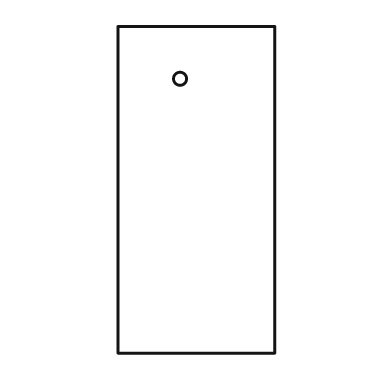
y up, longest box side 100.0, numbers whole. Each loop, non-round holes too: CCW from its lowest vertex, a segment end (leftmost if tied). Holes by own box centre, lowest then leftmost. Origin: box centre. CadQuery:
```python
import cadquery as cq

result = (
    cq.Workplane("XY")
    .moveTo(-24.0, -50.0)
    .lineTo(24.0, -50.0)
    .lineTo(24.0, 50.0)
    .lineTo(-24.0, 50.0)
    .close()
    .moveTo(-5.0, 34.0)
    .circle(2.0)
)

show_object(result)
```